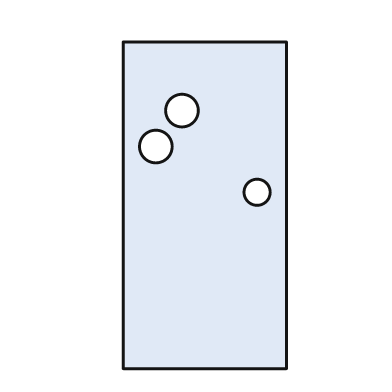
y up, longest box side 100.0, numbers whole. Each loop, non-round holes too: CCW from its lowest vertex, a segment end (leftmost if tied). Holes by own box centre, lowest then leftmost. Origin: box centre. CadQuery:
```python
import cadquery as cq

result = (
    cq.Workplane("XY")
    .moveTo(-25.0, -50.0)
    .lineTo(25.0, -50.0)
    .lineTo(25.0, 50.0)
    .lineTo(-25.0, 50.0)
    .close()
    .moveTo(16.0, 4.0)
    .circle(4.0)
    .moveTo(-15.0, 18.0)
    .circle(5.0)
    .moveTo(-7.0, 29.0)
    .circle(5.0)
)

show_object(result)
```